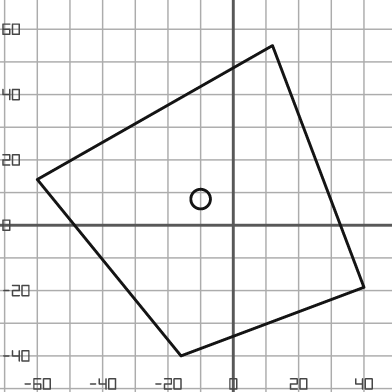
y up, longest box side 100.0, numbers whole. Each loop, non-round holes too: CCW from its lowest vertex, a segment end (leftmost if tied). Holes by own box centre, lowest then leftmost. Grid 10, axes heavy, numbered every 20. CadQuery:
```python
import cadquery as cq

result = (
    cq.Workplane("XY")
    .moveTo(-16.0, -40.0)
    .lineTo(40.0, -19.0)
    .lineTo(12.0, 55.0)
    .lineTo(-60.0, 14.0)
    .close()
    .moveTo(-10.0, 8.0)
    .circle(3.0)
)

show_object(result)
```